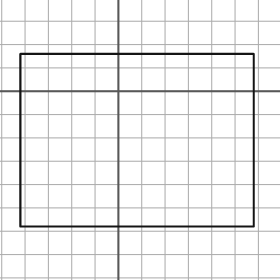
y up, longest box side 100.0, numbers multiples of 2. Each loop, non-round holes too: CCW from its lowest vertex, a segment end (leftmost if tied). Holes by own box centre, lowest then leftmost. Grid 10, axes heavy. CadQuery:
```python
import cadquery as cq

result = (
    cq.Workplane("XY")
    .moveTo(-42.0, -58.0)
    .lineTo(58.0, -58.0)
    .lineTo(58.0, 16.0)
    .lineTo(-42.0, 16.0)
    .close()
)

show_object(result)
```